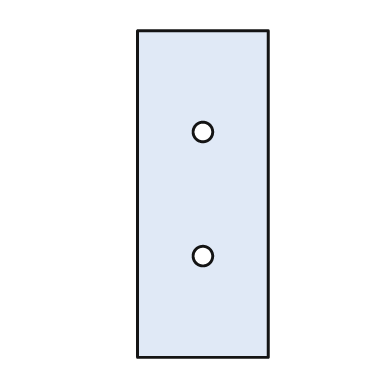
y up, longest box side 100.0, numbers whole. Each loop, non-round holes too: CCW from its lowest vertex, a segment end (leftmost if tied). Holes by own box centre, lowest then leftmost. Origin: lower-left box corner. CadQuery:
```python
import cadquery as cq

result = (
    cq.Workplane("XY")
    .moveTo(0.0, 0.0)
    .lineTo(40.0, 0.0)
    .lineTo(40.0, 100.0)
    .lineTo(0.0, 100.0)
    .close()
    .moveTo(20.0, 31.0)
    .circle(3.0)
    .moveTo(20.0, 69.0)
    .circle(3.0)
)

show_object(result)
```